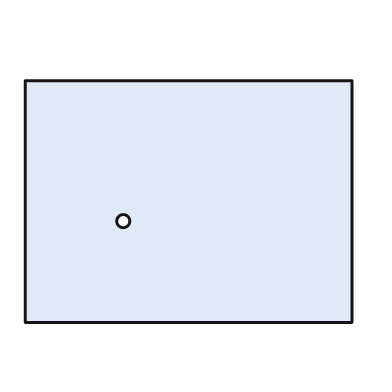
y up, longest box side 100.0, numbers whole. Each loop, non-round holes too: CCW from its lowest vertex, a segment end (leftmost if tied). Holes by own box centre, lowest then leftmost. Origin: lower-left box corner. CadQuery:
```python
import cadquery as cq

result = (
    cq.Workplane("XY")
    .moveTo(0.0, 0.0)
    .lineTo(100.0, 0.0)
    .lineTo(100.0, 74.0)
    .lineTo(0.0, 74.0)
    .close()
    .moveTo(30.0, 31.0)
    .circle(2.0)
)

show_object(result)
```